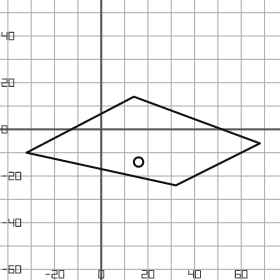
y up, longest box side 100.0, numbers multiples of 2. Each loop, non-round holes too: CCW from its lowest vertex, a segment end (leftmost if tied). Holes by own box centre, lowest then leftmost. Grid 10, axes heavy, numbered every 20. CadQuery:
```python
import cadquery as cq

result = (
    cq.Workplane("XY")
    .moveTo(32.0, -24.0)
    .lineTo(68.0, -6.0)
    .lineTo(14.0, 14.0)
    .lineTo(-32.0, -10.0)
    .close()
    .moveTo(16.0, -14.0)
    .circle(2.0)
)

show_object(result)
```